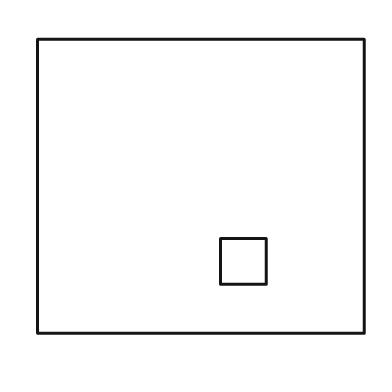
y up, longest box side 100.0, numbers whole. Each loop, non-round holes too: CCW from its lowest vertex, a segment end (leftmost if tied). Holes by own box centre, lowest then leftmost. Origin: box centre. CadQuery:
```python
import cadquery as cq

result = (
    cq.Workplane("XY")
    .moveTo(-50.0, -45.0)
    .lineTo(50.0, -45.0)
    .lineTo(50.0, 45.0)
    .lineTo(-50.0, 45.0)
    .close()
    .moveTo(6.0, -30.0)
    .lineTo(20.0, -30.0)
    .lineTo(20.0, -16.0)
    .lineTo(6.0, -16.0)
    .close()
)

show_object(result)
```